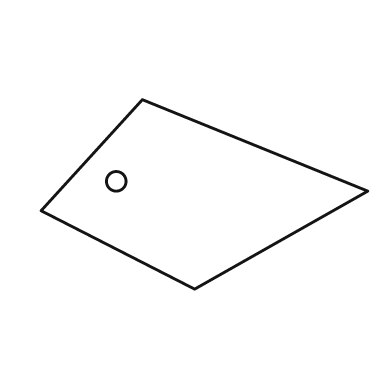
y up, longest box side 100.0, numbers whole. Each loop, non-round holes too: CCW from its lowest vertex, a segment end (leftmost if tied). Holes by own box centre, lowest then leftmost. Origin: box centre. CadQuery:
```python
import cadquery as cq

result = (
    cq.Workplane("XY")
    .moveTo(-3.0, -29.0)
    .lineTo(50.0, 1.0)
    .lineTo(-19.0, 29.0)
    .lineTo(-50.0, -5.0)
    .close()
    .moveTo(-27.0, 4.0)
    .circle(3.0)
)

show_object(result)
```